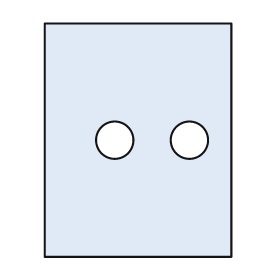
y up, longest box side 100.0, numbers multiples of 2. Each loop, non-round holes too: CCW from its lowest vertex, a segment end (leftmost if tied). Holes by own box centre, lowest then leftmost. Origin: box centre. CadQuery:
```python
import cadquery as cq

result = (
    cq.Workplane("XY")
    .moveTo(-40.0, -50.0)
    .lineTo(40.0, -50.0)
    .lineTo(40.0, 50.0)
    .lineTo(-40.0, 50.0)
    .close()
    .moveTo(-10.0, 0.0)
    .circle(8.0)
    .moveTo(22.0, 0.0)
    .circle(8.0)
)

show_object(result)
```